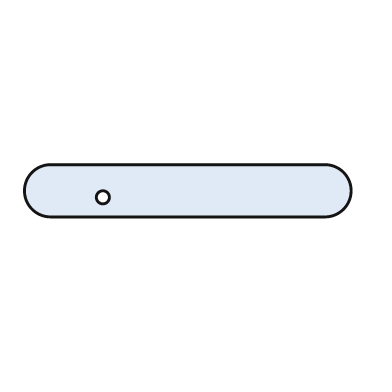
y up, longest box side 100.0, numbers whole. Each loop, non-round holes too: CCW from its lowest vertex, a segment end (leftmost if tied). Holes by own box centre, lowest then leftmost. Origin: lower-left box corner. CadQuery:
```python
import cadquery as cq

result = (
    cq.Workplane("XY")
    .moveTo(8.0, 0.0)
    .lineTo(92.0, 0.0)
    .threePointArc((100.0, 8.0), (92.0, 16.0))
    .lineTo(8.0, 16.0)
    .threePointArc((0.0, 8.0), (8.0, 0.0))
    .close()
    .moveTo(24.0, 6.0)
    .circle(2.0)
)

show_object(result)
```